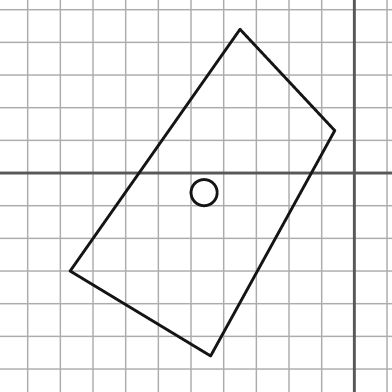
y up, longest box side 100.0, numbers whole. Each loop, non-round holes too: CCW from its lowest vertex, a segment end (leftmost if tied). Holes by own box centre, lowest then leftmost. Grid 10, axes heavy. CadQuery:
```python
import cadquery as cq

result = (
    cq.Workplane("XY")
    .moveTo(-44.0, -56.0)
    .lineTo(-6.0, 13.0)
    .lineTo(-35.0, 44.0)
    .lineTo(-87.0, -30.0)
    .close()
    .moveTo(-46.0, -6.0)
    .circle(4.0)
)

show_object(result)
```